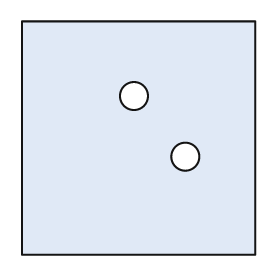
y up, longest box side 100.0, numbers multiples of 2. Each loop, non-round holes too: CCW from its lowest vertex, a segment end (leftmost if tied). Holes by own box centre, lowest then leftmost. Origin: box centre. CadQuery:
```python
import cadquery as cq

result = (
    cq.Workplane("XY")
    .moveTo(-50.0, -50.0)
    .lineTo(50.0, -50.0)
    .lineTo(50.0, 50.0)
    .lineTo(-50.0, 50.0)
    .close()
    .moveTo(20.0, -8.0)
    .circle(6.0)
    .moveTo(-2.0, 18.0)
    .circle(6.0)
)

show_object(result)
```